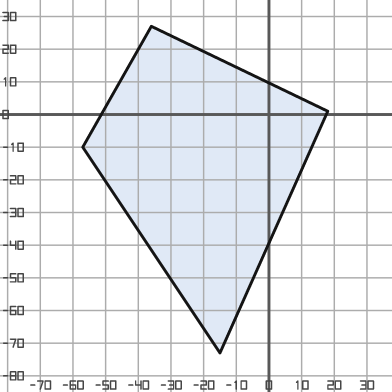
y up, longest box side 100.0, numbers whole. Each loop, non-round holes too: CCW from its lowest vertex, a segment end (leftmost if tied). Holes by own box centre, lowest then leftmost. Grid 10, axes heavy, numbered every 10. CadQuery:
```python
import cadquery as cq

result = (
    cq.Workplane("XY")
    .moveTo(-15.0, -73.0)
    .lineTo(18.0, 1.0)
    .lineTo(-36.0, 27.0)
    .lineTo(-57.0, -10.0)
    .close()
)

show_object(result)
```